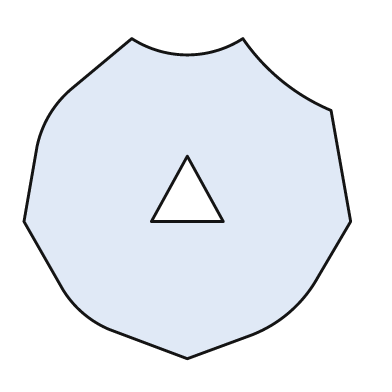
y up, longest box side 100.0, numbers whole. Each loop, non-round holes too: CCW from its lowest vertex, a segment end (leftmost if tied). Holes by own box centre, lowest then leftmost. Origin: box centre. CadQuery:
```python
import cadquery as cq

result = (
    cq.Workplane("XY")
    .moveTo(0.0, -49.0)
    .lineTo(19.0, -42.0)
    .threePointArc((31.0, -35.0), (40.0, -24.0))
    .lineTo(50.0, -7.0)
    .lineTo(44.0, 27.0)
    .threePointArc((29.0, 36.0), (17.0, 49.0))
    .threePointArc((0.0, 44.0), (-17.0, 49.0))
    .lineTo(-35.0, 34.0)
    .threePointArc((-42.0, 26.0), (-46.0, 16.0))
    .lineTo(-50.0, -7.0)
    .lineTo(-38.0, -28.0)
    .threePointArc((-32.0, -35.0), (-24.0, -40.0))
    .close()
    .moveTo(-11.0, -7.0)
    .lineTo(11.0, -7.0)
    .lineTo(0.0, 13.0)
    .close()
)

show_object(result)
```